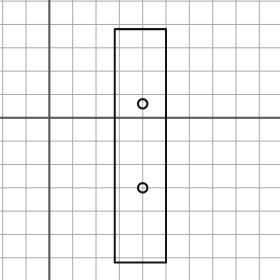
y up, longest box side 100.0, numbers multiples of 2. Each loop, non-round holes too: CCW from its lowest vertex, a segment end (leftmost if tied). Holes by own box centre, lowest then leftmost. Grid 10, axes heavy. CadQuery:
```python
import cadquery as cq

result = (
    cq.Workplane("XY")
    .moveTo(28.0, -62.0)
    .lineTo(50.0, -62.0)
    .lineTo(50.0, 38.0)
    .lineTo(28.0, 38.0)
    .close()
    .moveTo(40.0, -30.0)
    .circle(2.0)
    .moveTo(40.0, 6.0)
    .circle(2.0)
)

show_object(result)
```